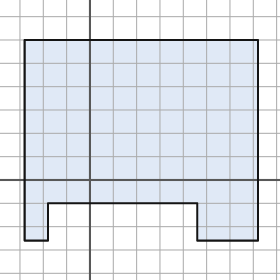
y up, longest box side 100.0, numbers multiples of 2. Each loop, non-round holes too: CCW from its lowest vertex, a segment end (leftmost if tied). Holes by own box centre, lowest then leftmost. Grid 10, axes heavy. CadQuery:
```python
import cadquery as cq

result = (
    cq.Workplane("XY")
    .moveTo(-28.0, -26.0)
    .lineTo(-18.0, -26.0)
    .lineTo(-18.0, -10.0)
    .lineTo(46.0, -10.0)
    .lineTo(46.0, -26.0)
    .lineTo(72.0, -26.0)
    .lineTo(72.0, 60.0)
    .lineTo(-28.0, 60.0)
    .close()
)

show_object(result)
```